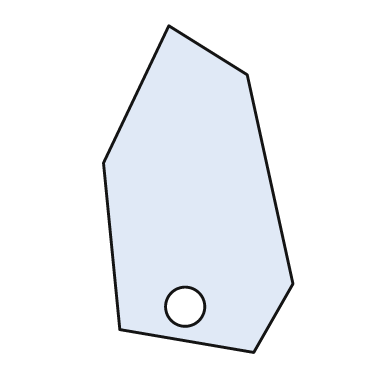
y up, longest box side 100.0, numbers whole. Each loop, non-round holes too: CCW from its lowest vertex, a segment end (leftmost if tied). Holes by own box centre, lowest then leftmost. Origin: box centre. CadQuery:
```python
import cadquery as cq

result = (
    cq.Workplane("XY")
    .moveTo(17.0, -50.0)
    .lineTo(29.0, -29.0)
    .lineTo(15.0, 35.0)
    .lineTo(-9.0, 50.0)
    .lineTo(-29.0, 8.0)
    .lineTo(-24.0, -43.0)
    .close()
    .moveTo(-4.0, -36.0)
    .circle(6.0)
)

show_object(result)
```